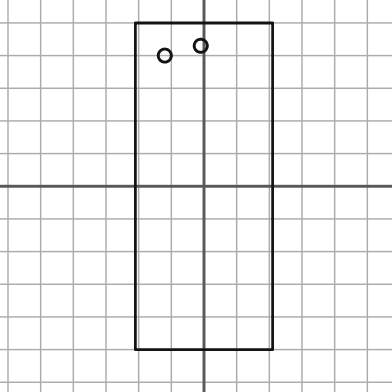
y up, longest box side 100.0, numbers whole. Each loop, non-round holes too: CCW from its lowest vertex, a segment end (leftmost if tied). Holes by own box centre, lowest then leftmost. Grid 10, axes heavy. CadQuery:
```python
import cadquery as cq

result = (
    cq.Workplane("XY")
    .moveTo(-21.0, -50.0)
    .lineTo(21.0, -50.0)
    .lineTo(21.0, 50.0)
    .lineTo(-21.0, 50.0)
    .close()
    .moveTo(-12.0, 40.0)
    .circle(2.0)
    .moveTo(-1.0, 43.0)
    .circle(2.0)
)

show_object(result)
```